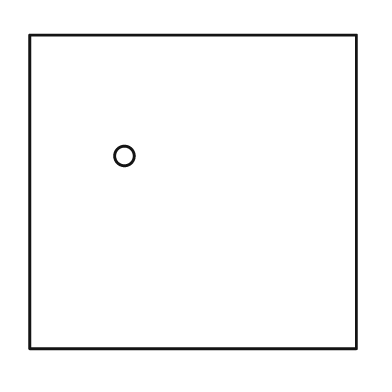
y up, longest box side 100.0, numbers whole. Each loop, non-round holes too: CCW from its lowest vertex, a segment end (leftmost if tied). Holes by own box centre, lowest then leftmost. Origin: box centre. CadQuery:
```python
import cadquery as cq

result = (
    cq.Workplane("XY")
    .moveTo(-50.0, -48.0)
    .lineTo(50.0, -48.0)
    .lineTo(50.0, 48.0)
    .lineTo(-50.0, 48.0)
    .close()
    .moveTo(-21.0, 11.0)
    .circle(3.0)
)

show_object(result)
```